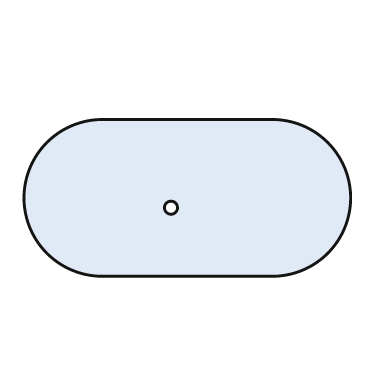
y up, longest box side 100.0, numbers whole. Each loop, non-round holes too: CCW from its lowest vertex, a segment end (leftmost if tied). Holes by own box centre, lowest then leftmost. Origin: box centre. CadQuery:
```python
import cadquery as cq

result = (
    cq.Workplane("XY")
    .moveTo(-26.0, -24.0)
    .lineTo(26.0, -24.0)
    .threePointArc((50.0, 0.0), (26.0, 24.0))
    .lineTo(-26.0, 24.0)
    .threePointArc((-50.0, 0.0), (-26.0, -24.0))
    .close()
    .moveTo(-5.0, -3.0)
    .circle(2.0)
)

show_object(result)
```